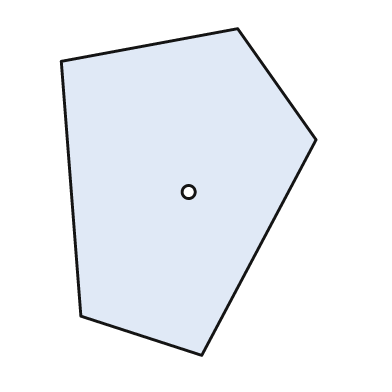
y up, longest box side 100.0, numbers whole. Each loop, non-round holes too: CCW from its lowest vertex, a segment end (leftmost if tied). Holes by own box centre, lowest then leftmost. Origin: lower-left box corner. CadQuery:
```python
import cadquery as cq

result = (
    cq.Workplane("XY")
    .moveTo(43.0, 0.0)
    .lineTo(78.0, 66.0)
    .lineTo(54.0, 100.0)
    .lineTo(0.0, 90.0)
    .lineTo(6.0, 12.0)
    .close()
    .moveTo(39.0, 50.0)
    .circle(2.0)
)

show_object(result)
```